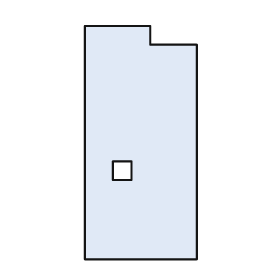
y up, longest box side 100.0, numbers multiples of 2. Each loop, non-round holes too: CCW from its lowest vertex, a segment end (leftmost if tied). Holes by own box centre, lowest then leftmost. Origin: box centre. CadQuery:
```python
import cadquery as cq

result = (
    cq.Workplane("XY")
    .moveTo(-24.0, -50.0)
    .lineTo(24.0, -50.0)
    .lineTo(24.0, 42.0)
    .lineTo(4.0, 42.0)
    .lineTo(4.0, 50.0)
    .lineTo(-24.0, 50.0)
    .close()
    .moveTo(-12.0, -16.0)
    .lineTo(-4.0, -16.0)
    .lineTo(-4.0, -8.0)
    .lineTo(-12.0, -8.0)
    .close()
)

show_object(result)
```